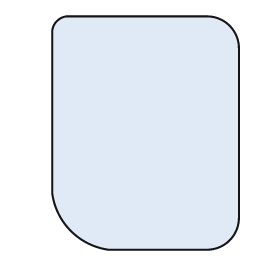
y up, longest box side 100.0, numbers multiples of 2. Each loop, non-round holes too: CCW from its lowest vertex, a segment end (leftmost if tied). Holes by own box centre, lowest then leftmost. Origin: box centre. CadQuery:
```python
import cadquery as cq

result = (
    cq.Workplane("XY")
    .moveTo(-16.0, -50.0)
    .lineTo(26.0, -50.0)
    .threePointArc((36.0, -46.0), (40.0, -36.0))
    .lineTo(40.0, 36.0)
    .threePointArc((36.0, 46.0), (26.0, 50.0))
    .lineTo(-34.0, 50.0)
    .threePointArc((-38.0, 48.0), (-40.0, 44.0))
    .lineTo(-40.0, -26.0)
    .threePointArc((-32.0, -42.0), (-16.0, -50.0))
    .close()
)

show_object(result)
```